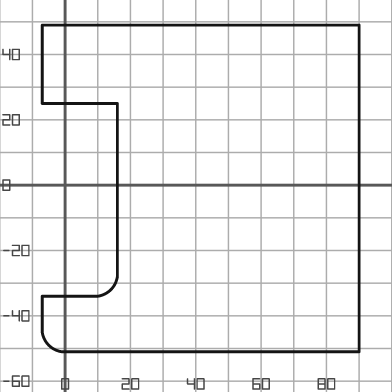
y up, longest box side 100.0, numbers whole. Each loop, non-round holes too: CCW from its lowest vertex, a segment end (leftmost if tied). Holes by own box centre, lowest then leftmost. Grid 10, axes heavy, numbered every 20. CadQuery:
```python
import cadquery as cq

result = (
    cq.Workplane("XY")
    .moveTo(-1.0, -51.0)
    .lineTo(90.0, -51.0)
    .lineTo(90.0, 49.0)
    .lineTo(-7.0, 49.0)
    .lineTo(-7.0, 25.0)
    .lineTo(16.0, 25.0)
    .lineTo(16.0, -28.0)
    .threePointArc((14.0, -32.0), (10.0, -34.0))
    .lineTo(-7.0, -34.0)
    .lineTo(-7.0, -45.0)
    .threePointArc((-5.0, -49.0), (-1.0, -51.0))
    .close()
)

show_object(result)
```